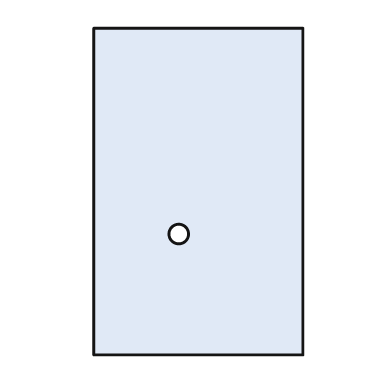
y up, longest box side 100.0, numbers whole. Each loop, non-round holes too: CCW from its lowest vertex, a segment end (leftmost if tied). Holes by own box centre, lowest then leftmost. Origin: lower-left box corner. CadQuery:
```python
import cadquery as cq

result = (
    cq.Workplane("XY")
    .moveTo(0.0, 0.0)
    .lineTo(64.0, 0.0)
    .lineTo(64.0, 100.0)
    .lineTo(0.0, 100.0)
    .close()
    .moveTo(26.0, 37.0)
    .circle(3.0)
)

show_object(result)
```